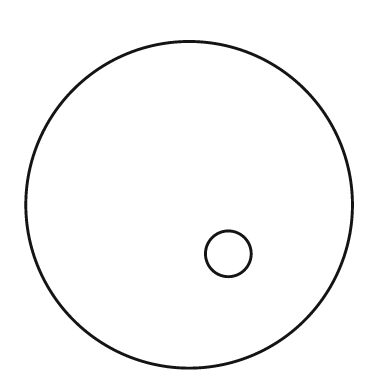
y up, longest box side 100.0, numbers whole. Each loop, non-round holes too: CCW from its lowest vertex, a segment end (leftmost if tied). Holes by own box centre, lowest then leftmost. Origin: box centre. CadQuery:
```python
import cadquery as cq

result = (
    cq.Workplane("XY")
    .moveTo(0.0, 0.0)
    .circle(50.0)
    .moveTo(12.0, -15.0)
    .circle(7.0)
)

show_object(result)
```